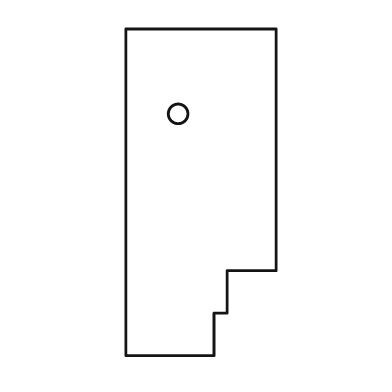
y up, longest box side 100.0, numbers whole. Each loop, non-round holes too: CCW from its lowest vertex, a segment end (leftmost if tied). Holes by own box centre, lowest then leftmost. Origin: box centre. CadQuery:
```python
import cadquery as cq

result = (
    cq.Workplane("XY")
    .moveTo(-23.0, -50.0)
    .lineTo(4.0, -50.0)
    .lineTo(4.0, -37.0)
    .lineTo(8.0, -37.0)
    .lineTo(8.0, -24.0)
    .lineTo(23.0, -24.0)
    .lineTo(23.0, 50.0)
    .lineTo(-23.0, 50.0)
    .close()
    .moveTo(-7.0, 24.0)
    .circle(3.0)
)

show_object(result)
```